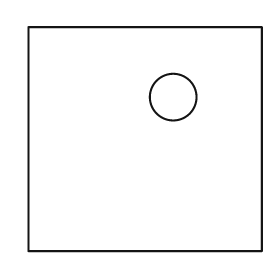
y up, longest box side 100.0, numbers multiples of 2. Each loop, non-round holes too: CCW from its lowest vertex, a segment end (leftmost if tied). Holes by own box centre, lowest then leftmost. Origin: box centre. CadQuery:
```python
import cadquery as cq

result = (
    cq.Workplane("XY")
    .moveTo(-50.0, -48.0)
    .lineTo(50.0, -48.0)
    .lineTo(50.0, 48.0)
    .lineTo(-50.0, 48.0)
    .close()
    .moveTo(12.0, 18.0)
    .circle(10.0)
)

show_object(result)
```